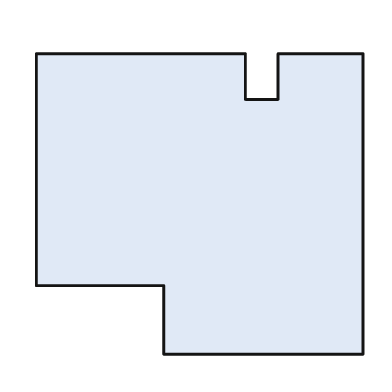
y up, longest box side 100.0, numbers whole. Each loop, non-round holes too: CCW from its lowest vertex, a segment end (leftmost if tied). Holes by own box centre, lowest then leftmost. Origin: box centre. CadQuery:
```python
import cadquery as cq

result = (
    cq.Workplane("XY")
    .moveTo(-11.0, -46.0)
    .lineTo(50.0, -46.0)
    .lineTo(50.0, 46.0)
    .lineTo(24.0, 46.0)
    .lineTo(24.0, 32.0)
    .lineTo(14.0, 32.0)
    .lineTo(14.0, 46.0)
    .lineTo(-50.0, 46.0)
    .lineTo(-50.0, -25.0)
    .lineTo(-11.0, -25.0)
    .close()
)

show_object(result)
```